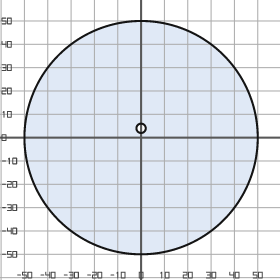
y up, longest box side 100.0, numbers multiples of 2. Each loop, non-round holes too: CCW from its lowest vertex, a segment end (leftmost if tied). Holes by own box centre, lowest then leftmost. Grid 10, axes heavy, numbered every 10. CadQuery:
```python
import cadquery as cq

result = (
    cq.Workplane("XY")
    .moveTo(0.0, 0.0)
    .circle(50.0)
    .moveTo(0.0, 4.0)
    .circle(2.0)
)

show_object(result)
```